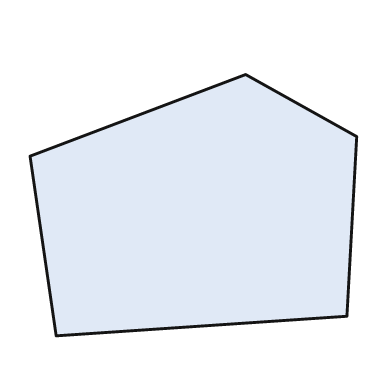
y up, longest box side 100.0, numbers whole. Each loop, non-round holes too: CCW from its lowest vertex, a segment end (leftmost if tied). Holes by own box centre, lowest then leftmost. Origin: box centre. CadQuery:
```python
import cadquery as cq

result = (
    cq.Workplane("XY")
    .moveTo(-42.0, -40.0)
    .lineTo(47.0, -34.0)
    .lineTo(50.0, 21.0)
    .lineTo(16.0, 40.0)
    .lineTo(-50.0, 15.0)
    .close()
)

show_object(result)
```